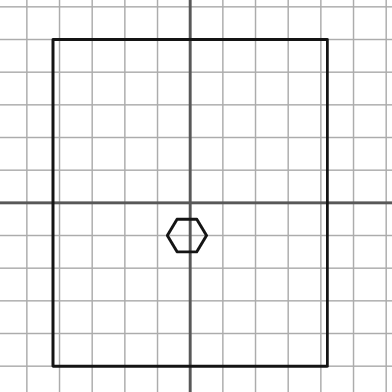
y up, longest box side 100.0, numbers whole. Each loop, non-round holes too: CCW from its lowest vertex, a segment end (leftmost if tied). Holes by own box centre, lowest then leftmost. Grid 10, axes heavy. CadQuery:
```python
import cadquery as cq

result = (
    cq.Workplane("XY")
    .moveTo(-42.0, -50.0)
    .lineTo(42.0, -50.0)
    .lineTo(42.0, 50.0)
    .lineTo(-42.0, 50.0)
    .close()
    .moveTo(-4.0, -15.0)
    .lineTo(2.0, -15.0)
    .lineTo(5.0, -10.0)
    .lineTo(2.0, -5.0)
    .lineTo(-4.0, -5.0)
    .lineTo(-7.0, -10.0)
    .close()
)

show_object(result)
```